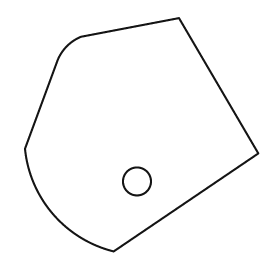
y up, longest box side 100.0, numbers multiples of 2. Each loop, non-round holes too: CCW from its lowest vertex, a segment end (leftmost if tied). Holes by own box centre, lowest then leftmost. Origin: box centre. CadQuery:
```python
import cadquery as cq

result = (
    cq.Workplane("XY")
    .moveTo(-12.0, -50.0)
    .lineTo(50.0, -8.0)
    .lineTo(16.0, 50.0)
    .lineTo(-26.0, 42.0)
    .threePointArc((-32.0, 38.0), (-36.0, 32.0))
    .lineTo(-50.0, -6.0)
    .threePointArc((-38.0, -34.0), (-12.0, -50.0))
    .close()
    .moveTo(-2.0, -20.0)
    .circle(6.0)
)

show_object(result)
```